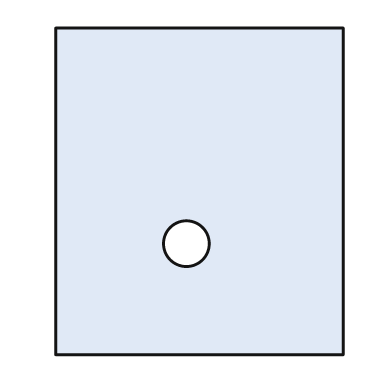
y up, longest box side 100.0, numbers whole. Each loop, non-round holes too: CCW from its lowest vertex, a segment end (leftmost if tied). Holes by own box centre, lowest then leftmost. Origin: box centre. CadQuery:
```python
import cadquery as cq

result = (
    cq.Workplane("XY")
    .moveTo(-44.0, -50.0)
    .lineTo(44.0, -50.0)
    .lineTo(44.0, 50.0)
    .lineTo(-44.0, 50.0)
    .close()
    .moveTo(-4.0, -16.0)
    .circle(7.0)
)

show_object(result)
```